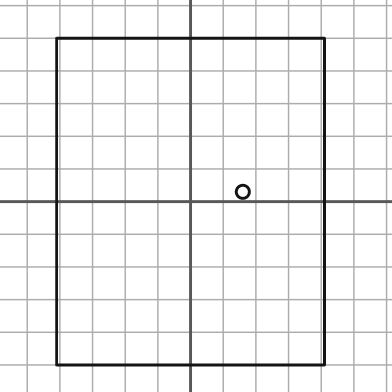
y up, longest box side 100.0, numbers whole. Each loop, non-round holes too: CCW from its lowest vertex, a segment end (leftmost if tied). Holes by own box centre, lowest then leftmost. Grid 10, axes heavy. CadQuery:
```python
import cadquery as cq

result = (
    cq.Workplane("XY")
    .moveTo(-41.0, -50.0)
    .lineTo(41.0, -50.0)
    .lineTo(41.0, 50.0)
    .lineTo(-41.0, 50.0)
    .close()
    .moveTo(16.0, 3.0)
    .circle(2.0)
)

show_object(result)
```